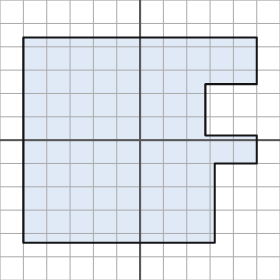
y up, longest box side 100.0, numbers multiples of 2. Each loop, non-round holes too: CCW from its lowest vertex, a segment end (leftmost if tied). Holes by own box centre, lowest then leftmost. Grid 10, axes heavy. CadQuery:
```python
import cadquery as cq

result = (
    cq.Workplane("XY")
    .moveTo(-50.0, -44.0)
    .lineTo(32.0, -44.0)
    .lineTo(32.0, -10.0)
    .lineTo(50.0, -10.0)
    .lineTo(50.0, 2.0)
    .lineTo(28.0, 2.0)
    .lineTo(28.0, 24.0)
    .lineTo(50.0, 24.0)
    .lineTo(50.0, 44.0)
    .lineTo(-50.0, 44.0)
    .close()
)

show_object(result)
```